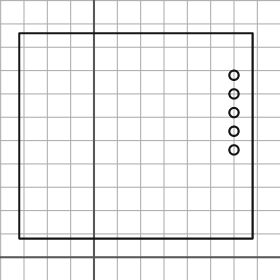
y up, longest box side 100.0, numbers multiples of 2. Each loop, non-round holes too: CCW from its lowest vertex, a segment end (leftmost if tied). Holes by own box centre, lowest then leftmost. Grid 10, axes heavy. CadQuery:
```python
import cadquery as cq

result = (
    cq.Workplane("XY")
    .moveTo(-32.0, 8.0)
    .lineTo(68.0, 8.0)
    .lineTo(68.0, 96.0)
    .lineTo(-32.0, 96.0)
    .close()
    .moveTo(60.0, 46.0)
    .circle(2.0)
    .moveTo(60.0, 54.0)
    .circle(2.0)
    .moveTo(60.0, 62.0)
    .circle(2.0)
    .moveTo(60.0, 70.0)
    .circle(2.0)
    .moveTo(60.0, 78.0)
    .circle(2.0)
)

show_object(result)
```